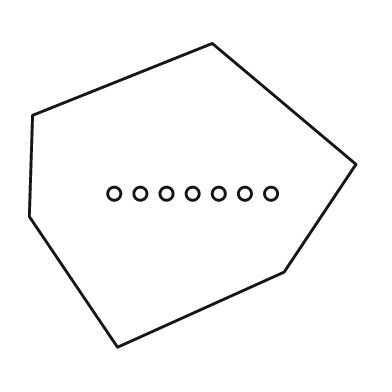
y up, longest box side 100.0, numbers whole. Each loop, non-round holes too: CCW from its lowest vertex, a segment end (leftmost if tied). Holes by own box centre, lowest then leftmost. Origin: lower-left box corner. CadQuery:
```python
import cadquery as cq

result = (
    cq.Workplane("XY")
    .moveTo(27.0, 0.0)
    .lineTo(78.0, 23.0)
    .lineTo(100.0, 56.0)
    .lineTo(56.0, 93.0)
    .lineTo(1.0, 71.0)
    .lineTo(0.0, 40.0)
    .close()
    .moveTo(26.0, 47.0)
    .circle(2.0)
    .moveTo(34.0, 47.0)
    .circle(2.0)
    .moveTo(42.0, 47.0)
    .circle(2.0)
    .moveTo(50.0, 47.0)
    .circle(2.0)
    .moveTo(58.0, 47.0)
    .circle(2.0)
    .moveTo(66.0, 47.0)
    .circle(2.0)
    .moveTo(74.0, 47.0)
    .circle(2.0)
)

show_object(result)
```